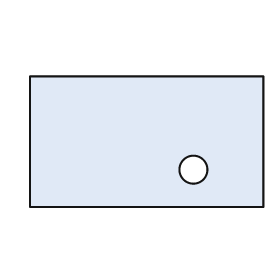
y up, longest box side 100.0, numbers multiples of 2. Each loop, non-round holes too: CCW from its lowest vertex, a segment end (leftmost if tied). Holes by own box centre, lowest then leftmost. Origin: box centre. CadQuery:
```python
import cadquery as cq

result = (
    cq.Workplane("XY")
    .moveTo(-50.0, -28.0)
    .lineTo(50.0, -28.0)
    .lineTo(50.0, 28.0)
    .lineTo(-50.0, 28.0)
    .close()
    .moveTo(20.0, -12.0)
    .circle(6.0)
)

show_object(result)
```